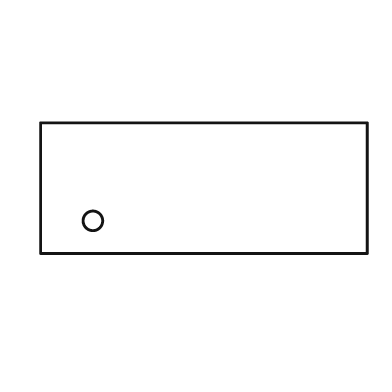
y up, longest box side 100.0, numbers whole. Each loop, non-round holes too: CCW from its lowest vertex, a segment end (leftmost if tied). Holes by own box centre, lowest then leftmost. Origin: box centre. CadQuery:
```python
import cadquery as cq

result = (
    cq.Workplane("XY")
    .moveTo(-50.0, -20.0)
    .lineTo(50.0, -20.0)
    .lineTo(50.0, 20.0)
    .lineTo(-50.0, 20.0)
    .close()
    .moveTo(-34.0, -10.0)
    .circle(3.0)
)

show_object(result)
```